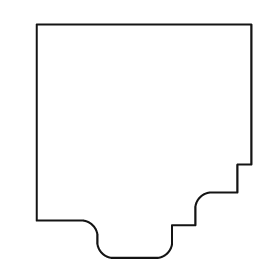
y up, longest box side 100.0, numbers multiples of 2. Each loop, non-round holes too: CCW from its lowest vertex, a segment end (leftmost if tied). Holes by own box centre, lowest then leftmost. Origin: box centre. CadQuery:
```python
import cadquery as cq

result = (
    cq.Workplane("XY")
    .moveTo(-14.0, -50.0)
    .lineTo(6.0, -50.0)
    .threePointArc((10.0, -48.0), (12.0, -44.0))
    .lineTo(12.0, -36.0)
    .lineTo(22.0, -36.0)
    .lineTo(22.0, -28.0)
    .threePointArc((24.0, -24.0), (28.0, -22.0))
    .lineTo(40.0, -22.0)
    .lineTo(40.0, -10.0)
    .lineTo(46.0, -10.0)
    .lineTo(46.0, 50.0)
    .lineTo(-46.0, 50.0)
    .lineTo(-46.0, -34.0)
    .lineTo(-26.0, -34.0)
    .threePointArc((-22.0, -36.0), (-20.0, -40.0))
    .lineTo(-20.0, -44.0)
    .threePointArc((-18.0, -48.0), (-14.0, -50.0))
    .close()
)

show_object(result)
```